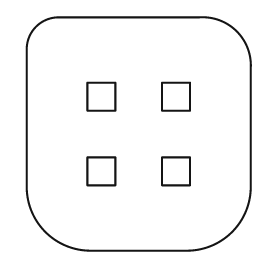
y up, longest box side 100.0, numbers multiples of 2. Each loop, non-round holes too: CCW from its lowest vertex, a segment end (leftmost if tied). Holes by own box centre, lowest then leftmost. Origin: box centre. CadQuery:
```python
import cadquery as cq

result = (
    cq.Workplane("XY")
    .moveTo(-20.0, -50.0)
    .lineTo(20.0, -50.0)
    .threePointArc((40.0, -42.0), (48.0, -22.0))
    .lineTo(48.0, 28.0)
    .threePointArc((42.0, 44.0), (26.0, 50.0))
    .lineTo(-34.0, 50.0)
    .threePointArc((-44.0, 46.0), (-48.0, 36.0))
    .lineTo(-48.0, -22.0)
    .threePointArc((-40.0, -42.0), (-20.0, -50.0))
    .close()
    .moveTo(-22.0, -22.0)
    .lineTo(-10.0, -22.0)
    .lineTo(-10.0, -10.0)
    .lineTo(-22.0, -10.0)
    .close()
    .moveTo(10.0, -22.0)
    .lineTo(22.0, -22.0)
    .lineTo(22.0, -10.0)
    .lineTo(10.0, -10.0)
    .close()
    .moveTo(-22.0, 10.0)
    .lineTo(-10.0, 10.0)
    .lineTo(-10.0, 22.0)
    .lineTo(-22.0, 22.0)
    .close()
    .moveTo(10.0, 10.0)
    .lineTo(22.0, 10.0)
    .lineTo(22.0, 22.0)
    .lineTo(10.0, 22.0)
    .close()
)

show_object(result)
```